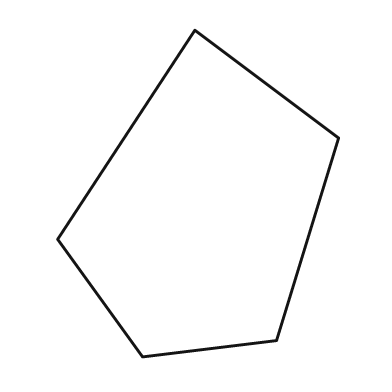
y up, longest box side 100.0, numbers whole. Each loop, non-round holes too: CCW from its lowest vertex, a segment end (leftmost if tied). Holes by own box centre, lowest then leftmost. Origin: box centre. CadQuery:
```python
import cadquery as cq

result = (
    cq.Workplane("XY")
    .moveTo(-17.0, -50.0)
    .lineTo(24.0, -45.0)
    .lineTo(43.0, 17.0)
    .lineTo(-1.0, 50.0)
    .lineTo(-43.0, -14.0)
    .close()
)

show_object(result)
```